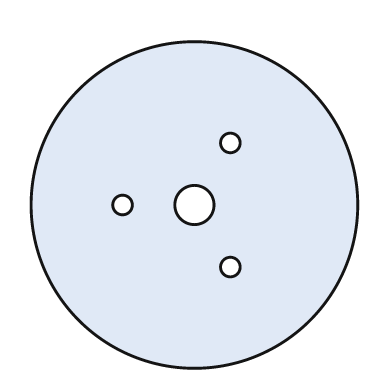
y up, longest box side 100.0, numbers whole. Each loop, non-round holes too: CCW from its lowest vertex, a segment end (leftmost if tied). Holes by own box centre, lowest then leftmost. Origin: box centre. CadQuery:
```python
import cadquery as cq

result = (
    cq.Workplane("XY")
    .moveTo(0.0, 0.0)
    .circle(50.0)
    .moveTo(11.0, -19.0)
    .circle(3.0)
    .moveTo(-22.0, 0.0)
    .circle(3.0)
    .moveTo(0.0, 0.0)
    .circle(6.0)
    .moveTo(11.0, 19.0)
    .circle(3.0)
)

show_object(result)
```